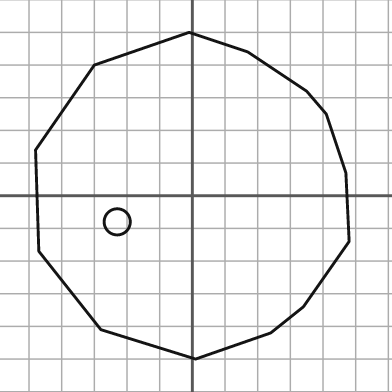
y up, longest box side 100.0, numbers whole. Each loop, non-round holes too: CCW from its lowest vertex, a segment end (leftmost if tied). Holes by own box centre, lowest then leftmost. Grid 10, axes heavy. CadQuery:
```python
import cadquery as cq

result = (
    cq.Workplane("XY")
    .moveTo(1.0, -50.0)
    .lineTo(24.0, -42.0)
    .lineTo(34.0, -34.0)
    .lineTo(48.0, -14.0)
    .lineTo(47.0, 7.0)
    .lineTo(41.0, 25.0)
    .lineTo(35.0, 32.0)
    .lineTo(17.0, 44.0)
    .lineTo(-1.0, 50.0)
    .lineTo(-30.0, 40.0)
    .lineTo(-48.0, 14.0)
    .lineTo(-47.0, -17.0)
    .lineTo(-28.0, -41.0)
    .close()
    .moveTo(-23.0, -8.0)
    .circle(4.0)
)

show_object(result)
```